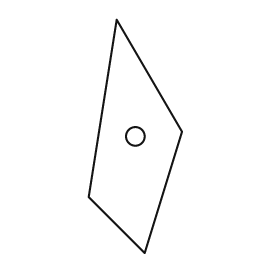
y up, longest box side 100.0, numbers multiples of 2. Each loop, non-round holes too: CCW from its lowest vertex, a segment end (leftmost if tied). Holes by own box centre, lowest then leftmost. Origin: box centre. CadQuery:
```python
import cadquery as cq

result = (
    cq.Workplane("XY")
    .moveTo(4.0, -50.0)
    .lineTo(20.0, 2.0)
    .lineTo(-8.0, 50.0)
    .lineTo(-20.0, -26.0)
    .close()
    .moveTo(0.0, 0.0)
    .circle(4.0)
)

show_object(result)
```